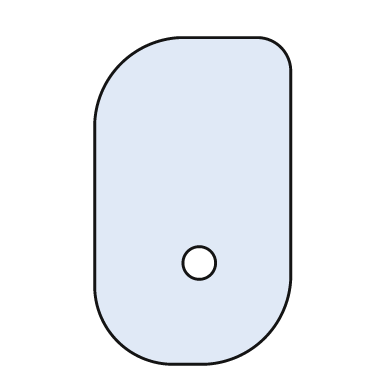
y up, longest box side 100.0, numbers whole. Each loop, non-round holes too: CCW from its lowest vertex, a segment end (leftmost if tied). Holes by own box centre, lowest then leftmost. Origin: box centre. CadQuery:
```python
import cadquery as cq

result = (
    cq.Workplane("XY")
    .moveTo(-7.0, -50.0)
    .lineTo(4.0, -50.0)
    .threePointArc((22.0, -42.0), (30.0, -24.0))
    .lineTo(30.0, 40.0)
    .threePointArc((27.0, 47.0), (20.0, 50.0))
    .lineTo(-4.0, 50.0)
    .threePointArc((-22.0, 42.0), (-30.0, 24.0))
    .lineTo(-30.0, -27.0)
    .threePointArc((-23.0, -43.0), (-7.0, -50.0))
    .close()
    .moveTo(2.0, -19.0)
    .circle(5.0)
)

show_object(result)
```